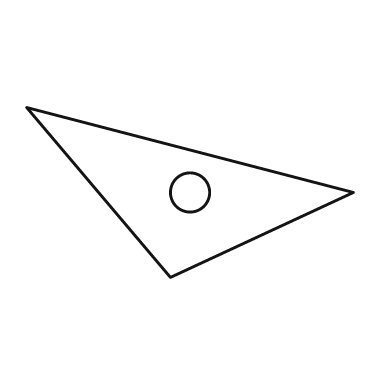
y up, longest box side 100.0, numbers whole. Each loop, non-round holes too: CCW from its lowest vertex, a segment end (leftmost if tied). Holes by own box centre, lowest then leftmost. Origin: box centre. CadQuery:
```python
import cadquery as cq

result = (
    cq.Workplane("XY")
    .moveTo(-6.0, -26.0)
    .lineTo(50.0, 0.0)
    .lineTo(-50.0, 26.0)
    .close()
    .moveTo(0.0, 0.0)
    .circle(6.0)
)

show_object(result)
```